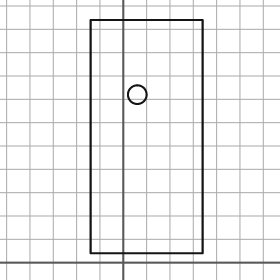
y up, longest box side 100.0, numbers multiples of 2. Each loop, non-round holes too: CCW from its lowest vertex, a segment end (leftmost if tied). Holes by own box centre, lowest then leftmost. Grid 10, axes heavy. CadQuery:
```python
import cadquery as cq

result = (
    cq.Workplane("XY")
    .moveTo(-14.0, 4.0)
    .lineTo(34.0, 4.0)
    .lineTo(34.0, 104.0)
    .lineTo(-14.0, 104.0)
    .close()
    .moveTo(6.0, 72.0)
    .circle(4.0)
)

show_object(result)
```